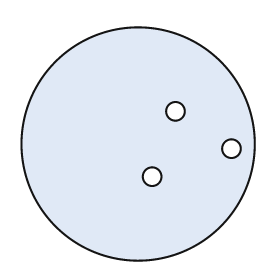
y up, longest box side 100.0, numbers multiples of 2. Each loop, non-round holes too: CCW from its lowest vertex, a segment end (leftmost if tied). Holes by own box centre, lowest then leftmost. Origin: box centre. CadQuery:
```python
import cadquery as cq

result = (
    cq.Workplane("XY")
    .moveTo(0.0, 0.0)
    .circle(50.0)
    .moveTo(6.0, -14.0)
    .circle(4.0)
    .moveTo(40.0, -2.0)
    .circle(4.0)
    .moveTo(16.0, 14.0)
    .circle(4.0)
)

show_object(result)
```